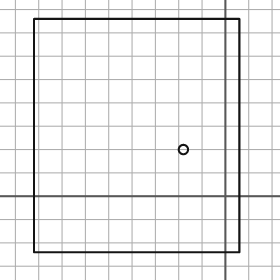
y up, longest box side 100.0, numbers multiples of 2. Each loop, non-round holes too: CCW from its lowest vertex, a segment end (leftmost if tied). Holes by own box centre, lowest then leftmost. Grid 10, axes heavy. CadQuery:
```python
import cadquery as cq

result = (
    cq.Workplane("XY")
    .moveTo(-82.0, -24.0)
    .lineTo(6.0, -24.0)
    .lineTo(6.0, 76.0)
    .lineTo(-82.0, 76.0)
    .close()
    .moveTo(-18.0, 20.0)
    .circle(2.0)
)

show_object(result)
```